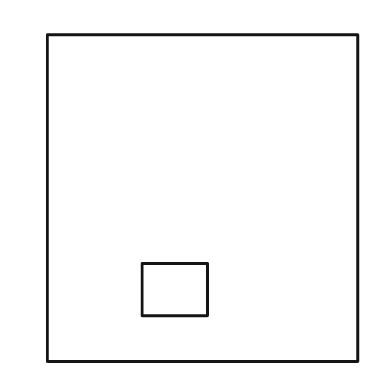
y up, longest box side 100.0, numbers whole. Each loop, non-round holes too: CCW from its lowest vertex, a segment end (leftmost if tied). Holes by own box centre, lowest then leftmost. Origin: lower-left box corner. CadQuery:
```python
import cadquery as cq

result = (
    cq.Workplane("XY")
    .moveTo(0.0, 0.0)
    .lineTo(95.0, 0.0)
    .lineTo(95.0, 100.0)
    .lineTo(0.0, 100.0)
    .close()
    .moveTo(29.0, 14.0)
    .lineTo(49.0, 14.0)
    .lineTo(49.0, 30.0)
    .lineTo(29.0, 30.0)
    .close()
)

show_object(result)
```